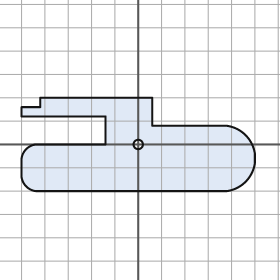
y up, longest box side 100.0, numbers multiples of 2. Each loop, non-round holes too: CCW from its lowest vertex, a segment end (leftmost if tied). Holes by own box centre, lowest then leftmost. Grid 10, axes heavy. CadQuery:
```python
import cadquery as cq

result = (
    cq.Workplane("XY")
    .moveTo(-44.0, -20.0)
    .lineTo(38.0, -20.0)
    .threePointArc((46.0, -16.0), (50.0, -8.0))
    .lineTo(50.0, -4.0)
    .threePointArc((46.0, 4.0), (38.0, 8.0))
    .lineTo(6.0, 8.0)
    .lineTo(6.0, 20.0)
    .lineTo(-42.0, 20.0)
    .lineTo(-42.0, 16.0)
    .lineTo(-50.0, 16.0)
    .lineTo(-50.0, 12.0)
    .lineTo(-14.0, 12.0)
    .lineTo(-14.0, 0.0)
    .lineTo(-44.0, 0.0)
    .threePointArc((-48.0, -2.0), (-50.0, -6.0))
    .lineTo(-50.0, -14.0)
    .threePointArc((-48.0, -18.0), (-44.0, -20.0))
    .close()
    .moveTo(0.0, 0.0)
    .circle(2.0)
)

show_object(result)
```